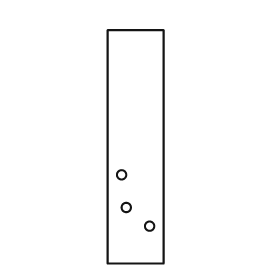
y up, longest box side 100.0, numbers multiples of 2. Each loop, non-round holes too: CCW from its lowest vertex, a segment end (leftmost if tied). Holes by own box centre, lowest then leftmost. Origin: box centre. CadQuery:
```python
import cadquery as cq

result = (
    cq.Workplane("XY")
    .moveTo(-12.0, -50.0)
    .lineTo(12.0, -50.0)
    .lineTo(12.0, 50.0)
    .lineTo(-12.0, 50.0)
    .close()
    .moveTo(6.0, -34.0)
    .circle(2.0)
    .moveTo(-4.0, -26.0)
    .circle(2.0)
    .moveTo(-6.0, -12.0)
    .circle(2.0)
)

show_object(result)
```